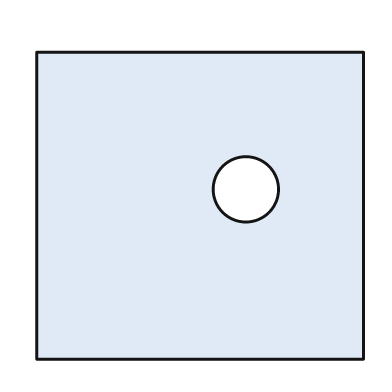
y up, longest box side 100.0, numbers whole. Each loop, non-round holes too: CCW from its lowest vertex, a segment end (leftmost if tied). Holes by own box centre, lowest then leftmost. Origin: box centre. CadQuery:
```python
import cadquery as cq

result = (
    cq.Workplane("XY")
    .moveTo(-50.0, -47.0)
    .lineTo(50.0, -47.0)
    .lineTo(50.0, 47.0)
    .lineTo(-50.0, 47.0)
    .close()
    .moveTo(14.0, 5.0)
    .circle(10.0)
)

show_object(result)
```